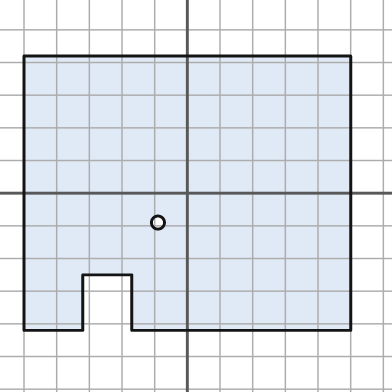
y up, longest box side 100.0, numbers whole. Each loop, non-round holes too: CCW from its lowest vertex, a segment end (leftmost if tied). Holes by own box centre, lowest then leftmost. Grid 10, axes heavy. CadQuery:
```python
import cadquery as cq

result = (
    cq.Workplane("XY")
    .moveTo(-50.0, -42.0)
    .lineTo(-32.0, -42.0)
    .lineTo(-32.0, -25.0)
    .lineTo(-17.0, -25.0)
    .lineTo(-17.0, -42.0)
    .lineTo(50.0, -42.0)
    .lineTo(50.0, 42.0)
    .lineTo(-50.0, 42.0)
    .close()
    .moveTo(-9.0, -9.0)
    .circle(2.0)
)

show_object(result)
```